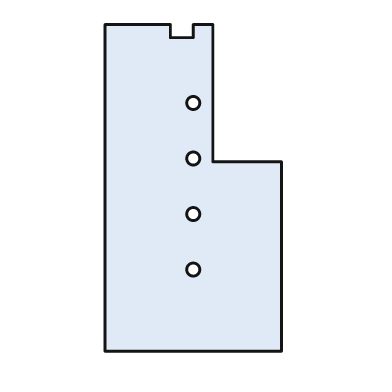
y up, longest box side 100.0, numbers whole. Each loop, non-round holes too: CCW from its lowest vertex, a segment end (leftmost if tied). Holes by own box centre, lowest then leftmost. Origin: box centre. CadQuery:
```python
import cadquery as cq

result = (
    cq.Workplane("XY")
    .moveTo(-27.0, -50.0)
    .lineTo(27.0, -50.0)
    .lineTo(27.0, 8.0)
    .lineTo(6.0, 8.0)
    .lineTo(6.0, 50.0)
    .lineTo(0.0, 50.0)
    .lineTo(0.0, 46.0)
    .lineTo(-7.0, 46.0)
    .lineTo(-7.0, 50.0)
    .lineTo(-27.0, 50.0)
    .close()
    .moveTo(0.0, -25.0)
    .circle(2.0)
    .moveTo(0.0, -8.0)
    .circle(2.0)
    .moveTo(0.0, 9.0)
    .circle(2.0)
    .moveTo(0.0, 26.0)
    .circle(2.0)
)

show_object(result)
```